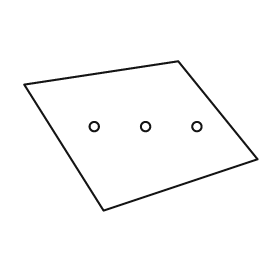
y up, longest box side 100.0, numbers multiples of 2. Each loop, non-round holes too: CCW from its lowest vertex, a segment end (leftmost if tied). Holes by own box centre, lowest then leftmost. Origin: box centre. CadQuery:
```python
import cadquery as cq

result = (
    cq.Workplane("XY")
    .moveTo(-16.0, -32.0)
    .lineTo(50.0, -10.0)
    .lineTo(16.0, 32.0)
    .lineTo(-50.0, 22.0)
    .close()
    .moveTo(-20.0, 4.0)
    .circle(2.0)
    .moveTo(2.0, 4.0)
    .circle(2.0)
    .moveTo(24.0, 4.0)
    .circle(2.0)
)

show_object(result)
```